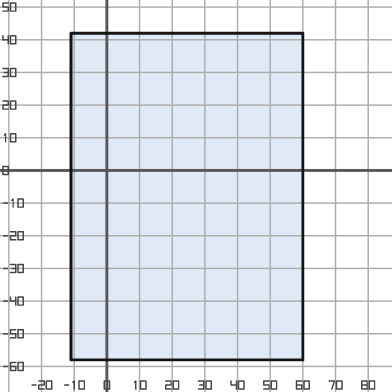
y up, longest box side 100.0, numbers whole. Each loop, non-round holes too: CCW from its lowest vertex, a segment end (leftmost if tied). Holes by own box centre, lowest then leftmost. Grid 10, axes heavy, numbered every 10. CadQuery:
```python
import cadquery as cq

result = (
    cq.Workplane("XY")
    .moveTo(-11.0, -58.0)
    .lineTo(60.0, -58.0)
    .lineTo(60.0, 42.0)
    .lineTo(-11.0, 42.0)
    .close()
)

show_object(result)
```